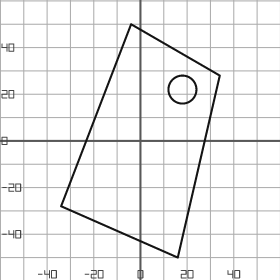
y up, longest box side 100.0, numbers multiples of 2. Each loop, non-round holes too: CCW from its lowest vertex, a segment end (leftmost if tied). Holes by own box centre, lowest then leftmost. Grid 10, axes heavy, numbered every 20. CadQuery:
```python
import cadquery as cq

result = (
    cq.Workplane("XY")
    .moveTo(16.0, -50.0)
    .lineTo(34.0, 28.0)
    .lineTo(-4.0, 50.0)
    .lineTo(-34.0, -28.0)
    .close()
    .moveTo(18.0, 22.0)
    .circle(6.0)
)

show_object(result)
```